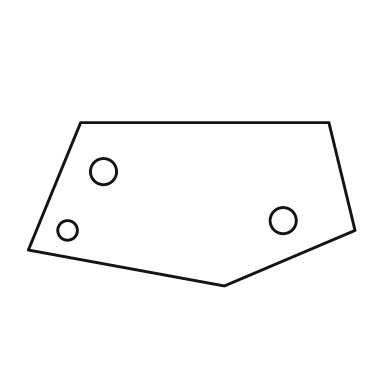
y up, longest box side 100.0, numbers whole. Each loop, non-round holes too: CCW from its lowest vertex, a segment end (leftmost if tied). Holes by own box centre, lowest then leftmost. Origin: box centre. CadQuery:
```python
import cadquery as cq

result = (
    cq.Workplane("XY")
    .moveTo(10.0, -25.0)
    .lineTo(50.0, -8.0)
    .lineTo(42.0, 25.0)
    .lineTo(-34.0, 25.0)
    .lineTo(-50.0, -14.0)
    .close()
    .moveTo(-38.0, -8.0)
    .circle(3.0)
    .moveTo(28.0, -5.0)
    .circle(4.0)
    .moveTo(-27.0, 10.0)
    .circle(4.0)
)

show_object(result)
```